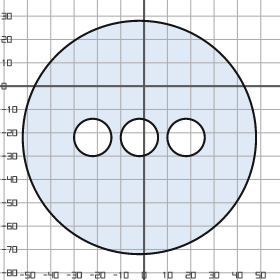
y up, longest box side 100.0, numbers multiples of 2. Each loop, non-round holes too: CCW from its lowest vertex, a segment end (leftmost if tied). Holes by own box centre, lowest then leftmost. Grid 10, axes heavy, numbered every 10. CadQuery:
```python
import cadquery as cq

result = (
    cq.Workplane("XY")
    .moveTo(-2.0, -22.0)
    .circle(50.0)
    .moveTo(-22.0, -22.0)
    .circle(8.0)
    .moveTo(-2.0, -22.0)
    .circle(8.0)
    .moveTo(18.0, -22.0)
    .circle(8.0)
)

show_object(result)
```